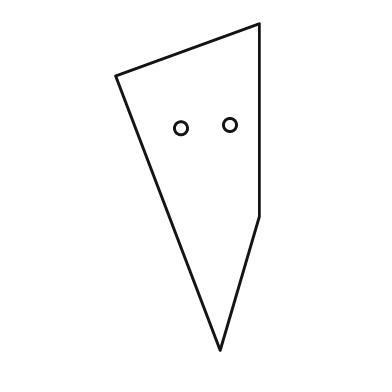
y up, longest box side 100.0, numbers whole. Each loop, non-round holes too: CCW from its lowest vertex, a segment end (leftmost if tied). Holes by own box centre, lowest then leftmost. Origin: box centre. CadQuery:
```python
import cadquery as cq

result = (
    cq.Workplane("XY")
    .moveTo(10.0, -50.0)
    .lineTo(22.0, -9.0)
    .lineTo(22.0, 50.0)
    .lineTo(-22.0, 34.0)
    .close()
    .moveTo(-2.0, 18.0)
    .circle(2.0)
    .moveTo(13.0, 19.0)
    .circle(2.0)
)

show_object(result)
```